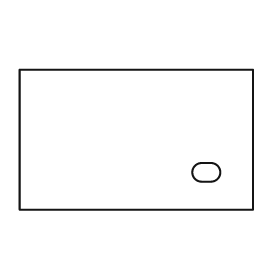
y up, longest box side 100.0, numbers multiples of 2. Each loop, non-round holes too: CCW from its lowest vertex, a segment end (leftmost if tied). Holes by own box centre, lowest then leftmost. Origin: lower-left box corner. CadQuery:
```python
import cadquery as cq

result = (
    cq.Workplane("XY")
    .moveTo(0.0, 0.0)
    .lineTo(100.0, 0.0)
    .lineTo(100.0, 60.0)
    .lineTo(0.0, 60.0)
    .close()
    .moveTo(78.0, 12.0)
    .lineTo(82.0, 12.0)
    .threePointArc((86.0, 16.0), (82.0, 20.0))
    .lineTo(78.0, 20.0)
    .threePointArc((74.0, 16.0), (78.0, 12.0))
    .close()
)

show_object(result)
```